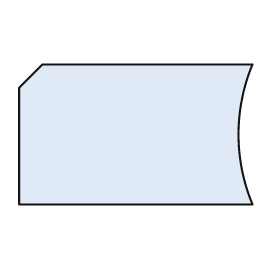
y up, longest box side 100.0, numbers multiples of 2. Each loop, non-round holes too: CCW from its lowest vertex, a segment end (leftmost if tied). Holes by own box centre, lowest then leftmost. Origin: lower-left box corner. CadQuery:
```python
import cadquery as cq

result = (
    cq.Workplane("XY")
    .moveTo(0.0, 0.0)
    .lineTo(100.0, 0.0)
    .threePointArc((94.0, 30.0), (100.0, 60.0))
    .lineTo(10.0, 60.0)
    .lineTo(0.0, 50.0)
    .close()
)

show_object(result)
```